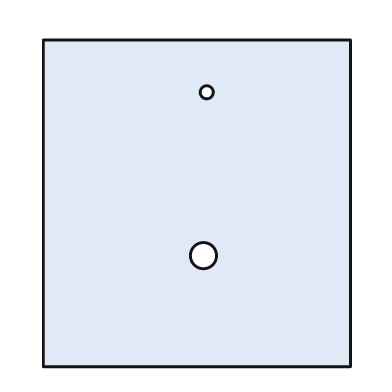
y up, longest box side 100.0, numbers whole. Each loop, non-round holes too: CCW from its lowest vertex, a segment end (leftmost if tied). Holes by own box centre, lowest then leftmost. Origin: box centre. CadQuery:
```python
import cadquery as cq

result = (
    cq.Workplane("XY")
    .moveTo(-47.0, -50.0)
    .lineTo(47.0, -50.0)
    .lineTo(47.0, 50.0)
    .lineTo(-47.0, 50.0)
    .close()
    .moveTo(2.0, -16.0)
    .circle(4.0)
    .moveTo(3.0, 34.0)
    .circle(2.0)
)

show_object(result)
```